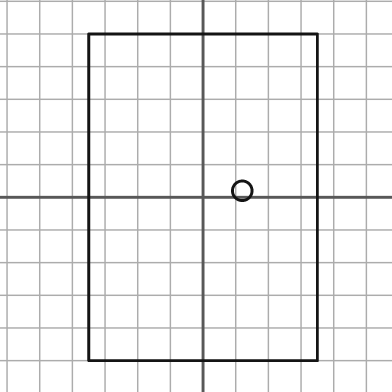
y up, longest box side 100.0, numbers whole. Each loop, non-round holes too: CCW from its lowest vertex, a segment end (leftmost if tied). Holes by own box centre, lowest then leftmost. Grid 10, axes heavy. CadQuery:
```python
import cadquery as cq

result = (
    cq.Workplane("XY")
    .moveTo(-35.0, -50.0)
    .lineTo(35.0, -50.0)
    .lineTo(35.0, 50.0)
    .lineTo(-35.0, 50.0)
    .close()
    .moveTo(12.0, 2.0)
    .circle(3.0)
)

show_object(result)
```